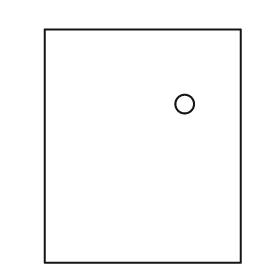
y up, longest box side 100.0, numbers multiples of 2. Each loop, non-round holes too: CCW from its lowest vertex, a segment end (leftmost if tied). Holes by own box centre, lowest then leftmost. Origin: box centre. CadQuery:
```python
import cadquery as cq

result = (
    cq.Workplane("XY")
    .moveTo(-42.0, -50.0)
    .lineTo(42.0, -50.0)
    .lineTo(42.0, 50.0)
    .lineTo(-42.0, 50.0)
    .close()
    .moveTo(18.0, 18.0)
    .circle(4.0)
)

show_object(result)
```